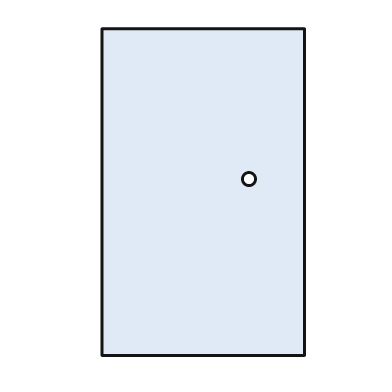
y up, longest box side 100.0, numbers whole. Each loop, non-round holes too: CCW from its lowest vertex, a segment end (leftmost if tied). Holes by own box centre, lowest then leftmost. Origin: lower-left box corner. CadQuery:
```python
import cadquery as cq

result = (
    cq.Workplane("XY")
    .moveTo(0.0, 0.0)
    .lineTo(62.0, 0.0)
    .lineTo(62.0, 100.0)
    .lineTo(0.0, 100.0)
    .close()
    .moveTo(45.0, 54.0)
    .circle(2.0)
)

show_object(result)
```